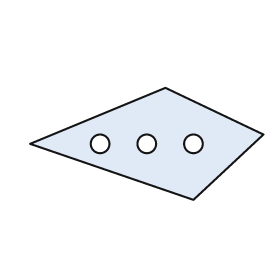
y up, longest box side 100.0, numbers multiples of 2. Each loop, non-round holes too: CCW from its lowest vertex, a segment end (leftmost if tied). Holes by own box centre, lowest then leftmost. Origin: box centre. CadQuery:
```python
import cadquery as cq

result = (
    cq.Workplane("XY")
    .moveTo(20.0, -24.0)
    .lineTo(50.0, 4.0)
    .lineTo(8.0, 24.0)
    .lineTo(-50.0, 0.0)
    .close()
    .moveTo(-20.0, 0.0)
    .circle(4.0)
    .moveTo(0.0, 0.0)
    .circle(4.0)
    .moveTo(20.0, 0.0)
    .circle(4.0)
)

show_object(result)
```